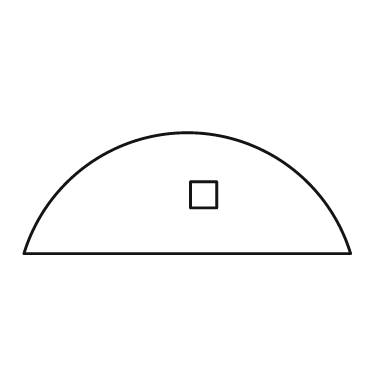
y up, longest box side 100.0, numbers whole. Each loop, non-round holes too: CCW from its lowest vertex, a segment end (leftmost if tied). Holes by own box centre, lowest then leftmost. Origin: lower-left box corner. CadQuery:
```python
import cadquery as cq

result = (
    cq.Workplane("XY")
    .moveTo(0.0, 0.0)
    .lineTo(100.0, 0.0)
    .threePointArc((50.0, 37.0), (0.0, 0.0))
    .close()
    .moveTo(51.0, 14.0)
    .lineTo(59.0, 14.0)
    .lineTo(59.0, 22.0)
    .lineTo(51.0, 22.0)
    .close()
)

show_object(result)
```